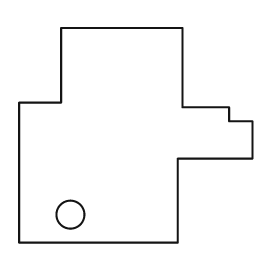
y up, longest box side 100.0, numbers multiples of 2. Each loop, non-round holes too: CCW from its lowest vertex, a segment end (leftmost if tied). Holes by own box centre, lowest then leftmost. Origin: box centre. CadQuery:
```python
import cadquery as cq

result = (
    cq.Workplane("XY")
    .moveTo(-50.0, -46.0)
    .lineTo(18.0, -46.0)
    .lineTo(18.0, -10.0)
    .lineTo(50.0, -10.0)
    .lineTo(50.0, 6.0)
    .lineTo(40.0, 6.0)
    .lineTo(40.0, 12.0)
    .lineTo(20.0, 12.0)
    .lineTo(20.0, 46.0)
    .lineTo(-32.0, 46.0)
    .lineTo(-32.0, 14.0)
    .lineTo(-50.0, 14.0)
    .close()
    .moveTo(-28.0, -34.0)
    .circle(6.0)
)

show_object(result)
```